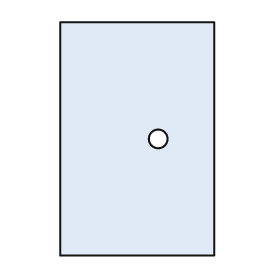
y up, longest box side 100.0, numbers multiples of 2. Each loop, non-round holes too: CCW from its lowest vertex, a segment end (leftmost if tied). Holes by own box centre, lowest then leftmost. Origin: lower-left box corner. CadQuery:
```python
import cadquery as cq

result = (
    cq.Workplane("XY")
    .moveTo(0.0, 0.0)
    .lineTo(66.0, 0.0)
    .lineTo(66.0, 100.0)
    .lineTo(0.0, 100.0)
    .close()
    .moveTo(42.0, 50.0)
    .circle(4.0)
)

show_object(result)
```